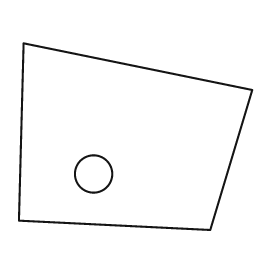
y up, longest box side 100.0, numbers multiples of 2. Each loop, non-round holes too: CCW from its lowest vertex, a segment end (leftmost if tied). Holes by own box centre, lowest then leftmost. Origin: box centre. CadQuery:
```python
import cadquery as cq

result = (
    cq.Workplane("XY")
    .moveTo(32.0, -40.0)
    .lineTo(50.0, 20.0)
    .lineTo(-48.0, 40.0)
    .lineTo(-50.0, -36.0)
    .close()
    .moveTo(-18.0, -16.0)
    .circle(8.0)
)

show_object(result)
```